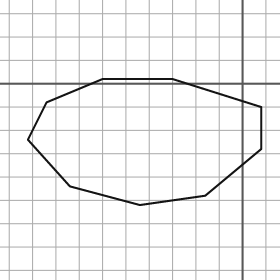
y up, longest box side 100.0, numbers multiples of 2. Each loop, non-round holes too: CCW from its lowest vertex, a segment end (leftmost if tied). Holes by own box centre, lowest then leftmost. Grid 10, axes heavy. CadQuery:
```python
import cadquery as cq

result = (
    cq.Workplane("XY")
    .moveTo(-44.0, -52.0)
    .lineTo(-16.0, -48.0)
    .lineTo(8.0, -28.0)
    .lineTo(8.0, -10.0)
    .lineTo(-30.0, 2.0)
    .lineTo(-60.0, 2.0)
    .lineTo(-84.0, -8.0)
    .lineTo(-92.0, -24.0)
    .lineTo(-74.0, -44.0)
    .close()
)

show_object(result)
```